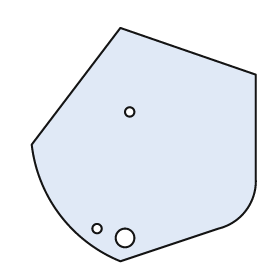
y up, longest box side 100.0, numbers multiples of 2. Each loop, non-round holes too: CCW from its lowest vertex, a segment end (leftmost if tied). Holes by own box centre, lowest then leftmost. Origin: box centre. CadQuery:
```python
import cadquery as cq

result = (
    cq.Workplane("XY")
    .moveTo(-10.0, -50.0)
    .lineTo(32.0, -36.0)
    .threePointArc((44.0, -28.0), (48.0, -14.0))
    .lineTo(48.0, 30.0)
    .lineTo(-10.0, 50.0)
    .lineTo(-48.0, 0.0)
    .threePointArc((-36.0, -30.0), (-10.0, -50.0))
    .close()
    .moveTo(-8.0, -40.0)
    .circle(4.0)
    .moveTo(-20.0, -36.0)
    .circle(2.0)
    .moveTo(-6.0, 14.0)
    .circle(2.0)
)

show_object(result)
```